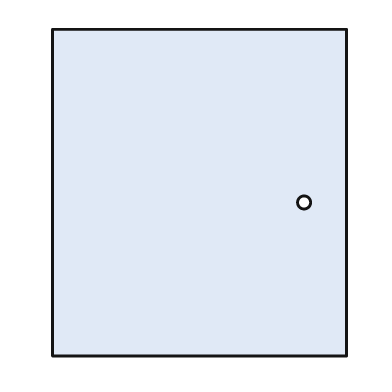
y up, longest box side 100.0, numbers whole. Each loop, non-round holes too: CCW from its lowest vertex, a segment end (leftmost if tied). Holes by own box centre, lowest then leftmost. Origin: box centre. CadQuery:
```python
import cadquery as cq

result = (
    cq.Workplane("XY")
    .moveTo(-45.0, -50.0)
    .lineTo(45.0, -50.0)
    .lineTo(45.0, 50.0)
    .lineTo(-45.0, 50.0)
    .close()
    .moveTo(32.0, -3.0)
    .circle(2.0)
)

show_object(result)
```